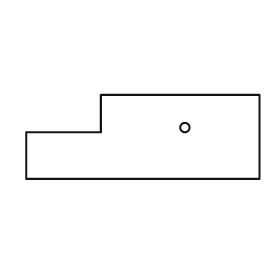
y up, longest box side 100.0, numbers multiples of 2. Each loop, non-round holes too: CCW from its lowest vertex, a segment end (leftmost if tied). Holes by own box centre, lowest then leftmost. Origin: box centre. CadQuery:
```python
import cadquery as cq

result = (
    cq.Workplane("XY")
    .moveTo(-50.0, -18.0)
    .lineTo(50.0, -18.0)
    .lineTo(50.0, 18.0)
    .lineTo(-18.0, 18.0)
    .lineTo(-18.0, 2.0)
    .lineTo(-50.0, 2.0)
    .close()
    .moveTo(18.0, 4.0)
    .circle(2.0)
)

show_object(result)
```